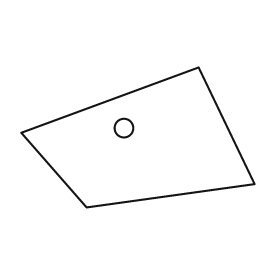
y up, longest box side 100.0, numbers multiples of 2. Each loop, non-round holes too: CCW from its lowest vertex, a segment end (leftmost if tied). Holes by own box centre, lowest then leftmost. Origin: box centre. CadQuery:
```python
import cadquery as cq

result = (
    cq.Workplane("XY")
    .moveTo(-22.0, -30.0)
    .lineTo(50.0, -20.0)
    .lineTo(26.0, 30.0)
    .lineTo(-50.0, 2.0)
    .close()
    .moveTo(-6.0, 4.0)
    .circle(4.0)
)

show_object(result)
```